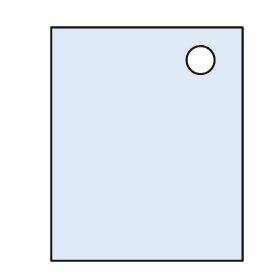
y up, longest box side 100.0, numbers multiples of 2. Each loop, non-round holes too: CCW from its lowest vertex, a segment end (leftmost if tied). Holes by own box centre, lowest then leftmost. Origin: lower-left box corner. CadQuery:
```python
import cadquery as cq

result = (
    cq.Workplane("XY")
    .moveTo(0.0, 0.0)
    .lineTo(82.0, 0.0)
    .lineTo(82.0, 100.0)
    .lineTo(0.0, 100.0)
    .close()
    .moveTo(64.0, 86.0)
    .circle(6.0)
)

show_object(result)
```